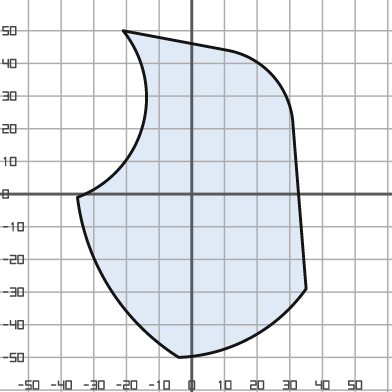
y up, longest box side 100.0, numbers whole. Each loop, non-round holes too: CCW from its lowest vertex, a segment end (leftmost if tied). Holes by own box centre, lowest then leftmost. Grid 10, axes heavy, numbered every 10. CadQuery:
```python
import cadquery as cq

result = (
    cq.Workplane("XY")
    .moveTo(-4.0, -50.0)
    .threePointArc((18.0, -44.0), (35.0, -29.0))
    .lineTo(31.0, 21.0)
    .threePointArc((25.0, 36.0), (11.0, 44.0))
    .lineTo(-21.0, 50.0)
    .threePointArc((-15.0, 21.0), (-35.0, -1.0))
    .threePointArc((-25.0, -29.0), (-4.0, -50.0))
    .close()
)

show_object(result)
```